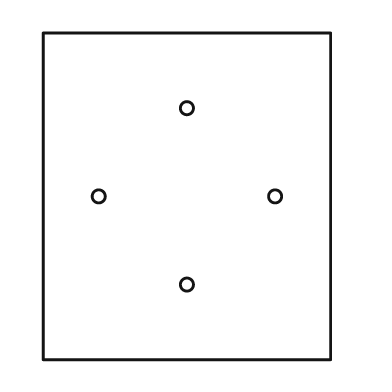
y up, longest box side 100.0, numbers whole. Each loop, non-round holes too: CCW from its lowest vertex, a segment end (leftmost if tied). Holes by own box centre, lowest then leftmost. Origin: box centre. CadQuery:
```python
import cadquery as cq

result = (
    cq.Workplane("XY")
    .moveTo(-44.0, -50.0)
    .lineTo(44.0, -50.0)
    .lineTo(44.0, 50.0)
    .lineTo(-44.0, 50.0)
    .close()
    .moveTo(0.0, -27.0)
    .circle(2.0)
    .moveTo(-27.0, 0.0)
    .circle(2.0)
    .moveTo(27.0, 0.0)
    .circle(2.0)
    .moveTo(0.0, 27.0)
    .circle(2.0)
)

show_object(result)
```